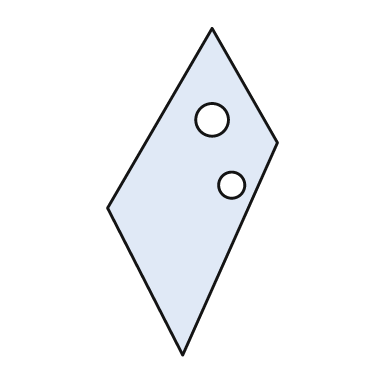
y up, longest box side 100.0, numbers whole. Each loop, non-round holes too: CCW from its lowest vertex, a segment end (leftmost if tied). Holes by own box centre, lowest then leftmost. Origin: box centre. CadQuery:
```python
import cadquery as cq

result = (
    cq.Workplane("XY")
    .moveTo(-3.0, -50.0)
    .lineTo(26.0, 15.0)
    .lineTo(6.0, 50.0)
    .lineTo(-26.0, -5.0)
    .close()
    .moveTo(12.0, 2.0)
    .circle(4.0)
    .moveTo(6.0, 22.0)
    .circle(5.0)
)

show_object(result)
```